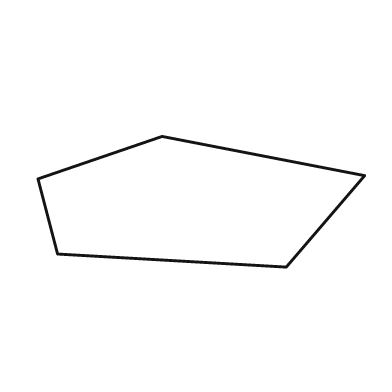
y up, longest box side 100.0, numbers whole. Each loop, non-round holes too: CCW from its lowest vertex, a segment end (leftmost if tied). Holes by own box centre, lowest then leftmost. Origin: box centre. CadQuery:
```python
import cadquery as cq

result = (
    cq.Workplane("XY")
    .moveTo(26.0, -20.0)
    .lineTo(50.0, 8.0)
    .lineTo(-12.0, 20.0)
    .lineTo(-50.0, 7.0)
    .lineTo(-44.0, -16.0)
    .close()
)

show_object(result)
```